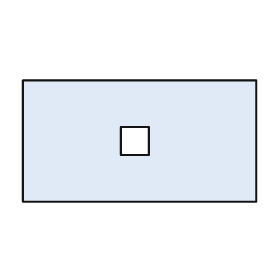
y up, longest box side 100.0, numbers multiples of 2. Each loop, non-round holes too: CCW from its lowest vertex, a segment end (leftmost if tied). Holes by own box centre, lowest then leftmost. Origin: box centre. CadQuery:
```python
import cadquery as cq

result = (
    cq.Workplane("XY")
    .moveTo(-50.0, -26.0)
    .lineTo(50.0, -26.0)
    .lineTo(50.0, 26.0)
    .lineTo(-50.0, 26.0)
    .close()
    .moveTo(-8.0, -6.0)
    .lineTo(4.0, -6.0)
    .lineTo(4.0, 6.0)
    .lineTo(-8.0, 6.0)
    .close()
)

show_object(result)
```